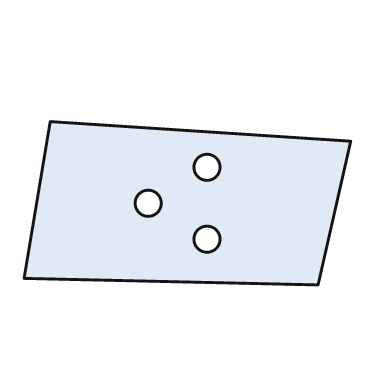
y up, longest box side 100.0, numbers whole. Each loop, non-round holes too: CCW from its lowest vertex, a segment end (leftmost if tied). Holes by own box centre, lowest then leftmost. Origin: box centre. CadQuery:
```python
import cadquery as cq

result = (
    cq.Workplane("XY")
    .moveTo(40.0, -25.0)
    .lineTo(50.0, 19.0)
    .lineTo(-42.0, 25.0)
    .lineTo(-50.0, -23.0)
    .close()
    .moveTo(6.0, -11.0)
    .circle(4.0)
    .moveTo(-12.0, 0.0)
    .circle(4.0)
    .moveTo(6.0, 11.0)
    .circle(4.0)
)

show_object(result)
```